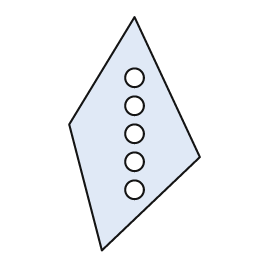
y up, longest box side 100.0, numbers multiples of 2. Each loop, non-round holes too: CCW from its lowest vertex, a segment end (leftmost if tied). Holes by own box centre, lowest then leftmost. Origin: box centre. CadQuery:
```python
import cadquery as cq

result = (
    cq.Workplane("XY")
    .moveTo(-14.0, -50.0)
    .lineTo(28.0, -10.0)
    .lineTo(0.0, 50.0)
    .lineTo(-28.0, 4.0)
    .close()
    .moveTo(0.0, -24.0)
    .circle(4.0)
    .moveTo(0.0, -12.0)
    .circle(4.0)
    .moveTo(0.0, 0.0)
    .circle(4.0)
    .moveTo(0.0, 12.0)
    .circle(4.0)
    .moveTo(0.0, 24.0)
    .circle(4.0)
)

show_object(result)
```